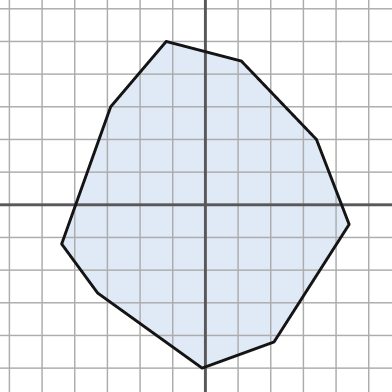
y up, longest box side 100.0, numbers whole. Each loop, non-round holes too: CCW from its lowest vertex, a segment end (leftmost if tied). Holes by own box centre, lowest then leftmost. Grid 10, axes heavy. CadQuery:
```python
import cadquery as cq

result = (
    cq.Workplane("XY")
    .moveTo(-1.0, -50.0)
    .lineTo(21.0, -42.0)
    .lineTo(44.0, -6.0)
    .lineTo(34.0, 20.0)
    .lineTo(11.0, 44.0)
    .lineTo(-12.0, 50.0)
    .lineTo(-29.0, 30.0)
    .lineTo(-44.0, -12.0)
    .lineTo(-33.0, -27.0)
    .close()
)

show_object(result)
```